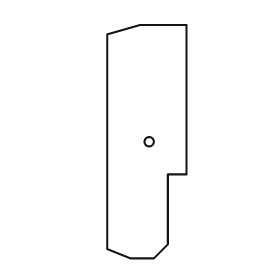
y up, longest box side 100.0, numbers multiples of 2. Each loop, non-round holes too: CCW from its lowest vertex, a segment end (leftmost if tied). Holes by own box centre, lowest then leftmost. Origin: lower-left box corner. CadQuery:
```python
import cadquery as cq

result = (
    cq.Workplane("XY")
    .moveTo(10.0, 0.0)
    .lineTo(20.0, 0.0)
    .lineTo(26.0, 6.0)
    .lineTo(26.0, 36.0)
    .lineTo(34.0, 36.0)
    .lineTo(34.0, 100.0)
    .lineTo(14.0, 100.0)
    .lineTo(0.0, 96.0)
    .lineTo(0.0, 4.0)
    .close()
    .moveTo(18.0, 50.0)
    .circle(2.0)
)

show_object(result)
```